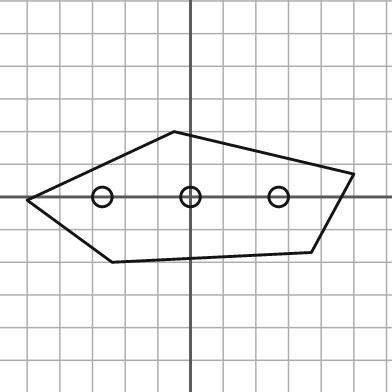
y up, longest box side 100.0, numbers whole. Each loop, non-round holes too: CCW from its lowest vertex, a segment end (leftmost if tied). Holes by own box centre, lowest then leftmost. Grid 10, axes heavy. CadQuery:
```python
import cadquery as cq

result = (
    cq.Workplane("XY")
    .moveTo(-24.0, -20.0)
    .lineTo(37.0, -17.0)
    .lineTo(50.0, 7.0)
    .lineTo(-5.0, 20.0)
    .lineTo(-50.0, -1.0)
    .close()
    .moveTo(-27.0, 0.0)
    .circle(3.0)
    .moveTo(0.0, 0.0)
    .circle(3.0)
    .moveTo(27.0, 0.0)
    .circle(3.0)
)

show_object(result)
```